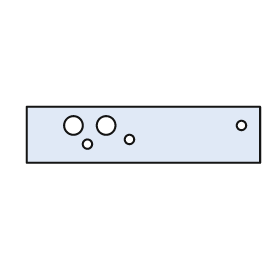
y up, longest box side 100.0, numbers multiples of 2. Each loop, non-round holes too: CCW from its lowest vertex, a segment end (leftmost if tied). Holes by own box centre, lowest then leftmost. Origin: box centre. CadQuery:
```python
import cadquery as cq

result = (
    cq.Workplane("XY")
    .moveTo(-50.0, -12.0)
    .lineTo(50.0, -12.0)
    .lineTo(50.0, 12.0)
    .lineTo(-50.0, 12.0)
    .close()
    .moveTo(-24.0, -4.0)
    .circle(2.0)
    .moveTo(-6.0, -2.0)
    .circle(2.0)
    .moveTo(-30.0, 4.0)
    .circle(4.0)
    .moveTo(-16.0, 4.0)
    .circle(4.0)
    .moveTo(42.0, 4.0)
    .circle(2.0)
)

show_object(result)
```